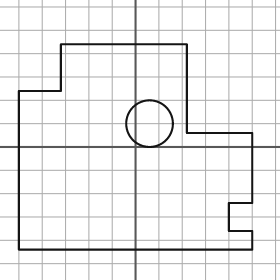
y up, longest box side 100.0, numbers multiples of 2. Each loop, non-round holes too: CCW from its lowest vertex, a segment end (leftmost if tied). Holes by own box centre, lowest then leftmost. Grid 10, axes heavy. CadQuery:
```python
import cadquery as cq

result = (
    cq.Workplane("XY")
    .moveTo(-50.0, -44.0)
    .lineTo(50.0, -44.0)
    .lineTo(50.0, -36.0)
    .lineTo(40.0, -36.0)
    .lineTo(40.0, -24.0)
    .lineTo(50.0, -24.0)
    .lineTo(50.0, 6.0)
    .lineTo(22.0, 6.0)
    .lineTo(22.0, 44.0)
    .lineTo(-32.0, 44.0)
    .lineTo(-32.0, 24.0)
    .lineTo(-50.0, 24.0)
    .close()
    .moveTo(6.0, 10.0)
    .circle(10.0)
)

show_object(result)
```